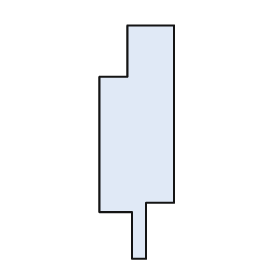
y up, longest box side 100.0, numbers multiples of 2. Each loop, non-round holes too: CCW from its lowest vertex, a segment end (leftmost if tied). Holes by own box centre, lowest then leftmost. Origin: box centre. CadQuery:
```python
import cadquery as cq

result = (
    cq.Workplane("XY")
    .moveTo(-2.0, -50.0)
    .lineTo(4.0, -50.0)
    .lineTo(4.0, -26.0)
    .lineTo(16.0, -26.0)
    .lineTo(16.0, 50.0)
    .lineTo(-4.0, 50.0)
    .lineTo(-4.0, 28.0)
    .lineTo(-16.0, 28.0)
    .lineTo(-16.0, -30.0)
    .lineTo(-2.0, -30.0)
    .close()
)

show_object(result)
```